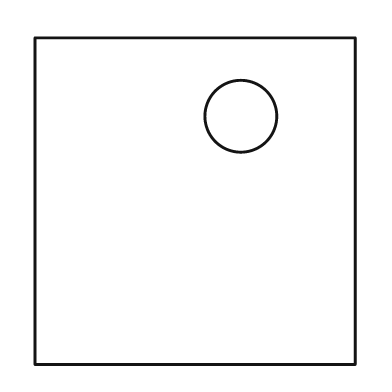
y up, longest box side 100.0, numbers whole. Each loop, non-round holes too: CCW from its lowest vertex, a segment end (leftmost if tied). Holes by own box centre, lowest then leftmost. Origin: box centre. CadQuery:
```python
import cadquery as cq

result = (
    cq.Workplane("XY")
    .moveTo(-49.0, -50.0)
    .lineTo(49.0, -50.0)
    .lineTo(49.0, 50.0)
    .lineTo(-49.0, 50.0)
    .close()
    .moveTo(14.0, 26.0)
    .circle(11.0)
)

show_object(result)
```